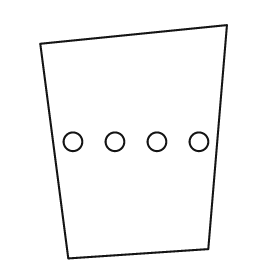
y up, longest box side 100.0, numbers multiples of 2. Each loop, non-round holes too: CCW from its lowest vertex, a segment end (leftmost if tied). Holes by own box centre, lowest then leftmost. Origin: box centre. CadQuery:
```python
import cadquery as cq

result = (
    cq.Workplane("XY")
    .moveTo(-28.0, -50.0)
    .lineTo(32.0, -46.0)
    .lineTo(40.0, 50.0)
    .lineTo(-40.0, 42.0)
    .close()
    .moveTo(-26.0, 0.0)
    .circle(4.0)
    .moveTo(-8.0, 0.0)
    .circle(4.0)
    .moveTo(10.0, 0.0)
    .circle(4.0)
    .moveTo(28.0, 0.0)
    .circle(4.0)
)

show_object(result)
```